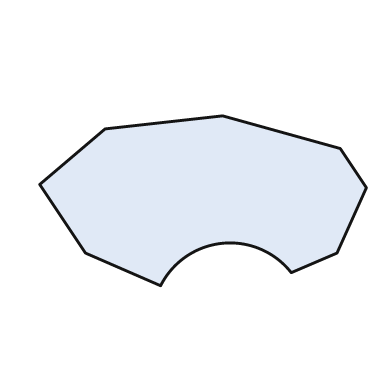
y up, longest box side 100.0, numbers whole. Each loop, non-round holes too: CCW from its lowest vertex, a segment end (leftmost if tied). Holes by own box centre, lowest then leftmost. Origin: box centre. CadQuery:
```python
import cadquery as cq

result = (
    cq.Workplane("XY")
    .moveTo(-13.0, -26.0)
    .threePointArc((6.0, -13.0), (27.0, -22.0))
    .lineTo(41.0, -16.0)
    .lineTo(50.0, 4.0)
    .lineTo(42.0, 16.0)
    .lineTo(6.0, 26.0)
    .lineTo(-30.0, 22.0)
    .lineTo(-50.0, 5.0)
    .lineTo(-36.0, -16.0)
    .close()
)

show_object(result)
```